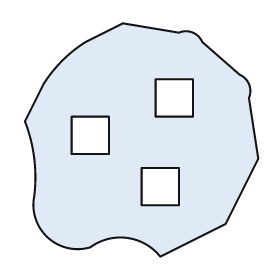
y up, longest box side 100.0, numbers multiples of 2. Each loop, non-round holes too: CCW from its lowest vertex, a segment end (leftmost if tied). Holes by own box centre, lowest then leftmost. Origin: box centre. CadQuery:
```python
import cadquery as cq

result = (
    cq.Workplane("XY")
    .moveTo(8.0, -50.0)
    .lineTo(36.0, -36.0)
    .lineTo(50.0, -8.0)
    .lineTo(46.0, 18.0)
    .threePointArc((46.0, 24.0), (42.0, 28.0))
    .lineTo(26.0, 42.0)
    .threePointArc((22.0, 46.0), (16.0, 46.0))
    .lineTo(-8.0, 50.0)
    .lineTo(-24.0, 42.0)
    .threePointArc((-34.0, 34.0), (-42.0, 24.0))
    .lineTo(-50.0, 8.0)
    .threePointArc((-46.0, -8.0), (-46.0, -24.0))
    .threePointArc((-40.0, -42.0), (-22.0, -46.0))
    .threePointArc((-6.0, -42.0), (8.0, -50.0))
    .close()
    .moveTo(0.0, -28.0)
    .lineTo(16.0, -28.0)
    .lineTo(16.0, -12.0)
    .lineTo(0.0, -12.0)
    .close()
    .moveTo(-30.0, -6.0)
    .lineTo(-14.0, -6.0)
    .lineTo(-14.0, 10.0)
    .lineTo(-30.0, 10.0)
    .close()
    .moveTo(6.0, 10.0)
    .lineTo(22.0, 10.0)
    .lineTo(22.0, 26.0)
    .lineTo(6.0, 26.0)
    .close()
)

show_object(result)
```